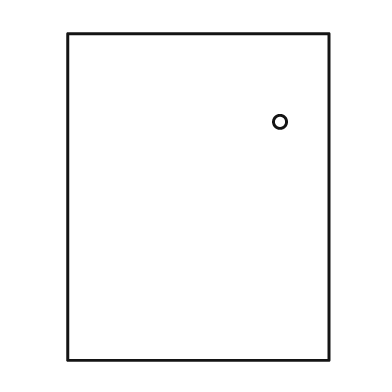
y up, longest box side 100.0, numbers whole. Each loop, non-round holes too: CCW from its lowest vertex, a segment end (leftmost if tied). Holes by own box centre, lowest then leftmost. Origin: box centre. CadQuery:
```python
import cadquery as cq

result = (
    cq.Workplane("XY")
    .moveTo(-40.0, -50.0)
    .lineTo(40.0, -50.0)
    .lineTo(40.0, 50.0)
    .lineTo(-40.0, 50.0)
    .close()
    .moveTo(25.0, 23.0)
    .circle(2.0)
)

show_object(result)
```